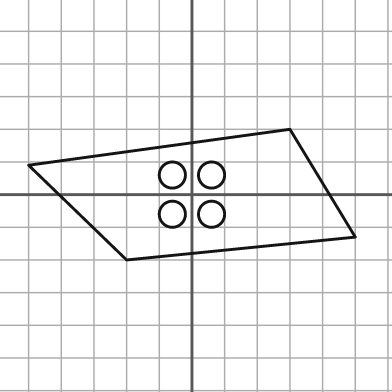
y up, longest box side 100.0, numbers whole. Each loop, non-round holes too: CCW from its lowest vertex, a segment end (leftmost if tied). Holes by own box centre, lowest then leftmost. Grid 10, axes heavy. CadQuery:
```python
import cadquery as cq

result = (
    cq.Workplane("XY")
    .moveTo(-20.0, -20.0)
    .lineTo(50.0, -13.0)
    .lineTo(30.0, 20.0)
    .lineTo(-50.0, 9.0)
    .close()
    .moveTo(-6.0, -6.0)
    .circle(4.0)
    .moveTo(6.0, -6.0)
    .circle(4.0)
    .moveTo(-6.0, 6.0)
    .circle(4.0)
    .moveTo(6.0, 6.0)
    .circle(4.0)
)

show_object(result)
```